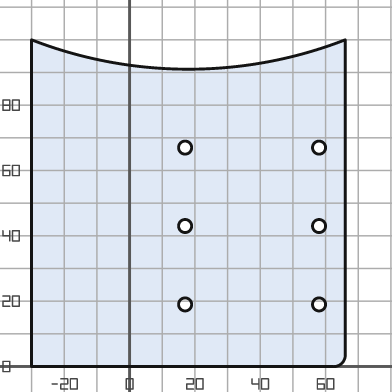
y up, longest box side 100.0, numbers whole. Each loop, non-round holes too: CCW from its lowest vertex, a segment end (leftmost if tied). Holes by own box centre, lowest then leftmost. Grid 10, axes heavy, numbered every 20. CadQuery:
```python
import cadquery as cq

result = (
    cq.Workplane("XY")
    .moveTo(-30.0, 0.0)
    .lineTo(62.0, 0.0)
    .threePointArc((65.0, 1.0), (66.0, 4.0))
    .lineTo(66.0, 100.0)
    .threePointArc((18.0, 91.0), (-30.0, 100.0))
    .close()
    .moveTo(17.0, 19.0)
    .circle(2.0)
    .moveTo(58.0, 19.0)
    .circle(2.0)
    .moveTo(17.0, 43.0)
    .circle(2.0)
    .moveTo(58.0, 43.0)
    .circle(2.0)
    .moveTo(17.0, 67.0)
    .circle(2.0)
    .moveTo(58.0, 67.0)
    .circle(2.0)
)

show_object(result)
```